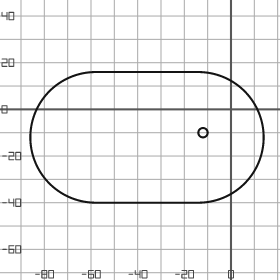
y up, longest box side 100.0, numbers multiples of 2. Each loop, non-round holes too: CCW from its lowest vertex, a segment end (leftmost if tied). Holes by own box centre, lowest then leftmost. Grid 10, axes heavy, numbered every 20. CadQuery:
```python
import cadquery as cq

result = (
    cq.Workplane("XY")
    .moveTo(-58.0, -40.0)
    .lineTo(-14.0, -40.0)
    .threePointArc((14.0, -12.0), (-14.0, 16.0))
    .lineTo(-58.0, 16.0)
    .threePointArc((-86.0, -12.0), (-58.0, -40.0))
    .close()
    .moveTo(-12.0, -10.0)
    .circle(2.0)
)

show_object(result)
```